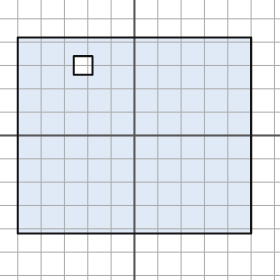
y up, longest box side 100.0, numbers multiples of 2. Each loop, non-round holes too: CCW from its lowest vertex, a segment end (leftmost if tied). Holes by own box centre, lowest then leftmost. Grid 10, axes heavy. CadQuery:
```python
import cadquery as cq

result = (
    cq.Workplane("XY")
    .moveTo(-50.0, -42.0)
    .lineTo(50.0, -42.0)
    .lineTo(50.0, 42.0)
    .lineTo(-50.0, 42.0)
    .close()
    .moveTo(-26.0, 26.0)
    .lineTo(-18.0, 26.0)
    .lineTo(-18.0, 34.0)
    .lineTo(-26.0, 34.0)
    .close()
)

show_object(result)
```